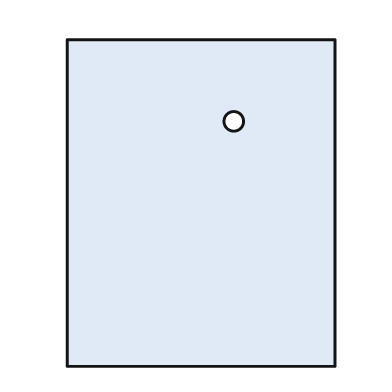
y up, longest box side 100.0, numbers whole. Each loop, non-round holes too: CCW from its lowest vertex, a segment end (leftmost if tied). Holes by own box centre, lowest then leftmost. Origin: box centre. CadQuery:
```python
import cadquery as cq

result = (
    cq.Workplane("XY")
    .moveTo(-41.0, -50.0)
    .lineTo(41.0, -50.0)
    .lineTo(41.0, 50.0)
    .lineTo(-41.0, 50.0)
    .close()
    .moveTo(10.0, 25.0)
    .circle(3.0)
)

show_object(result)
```